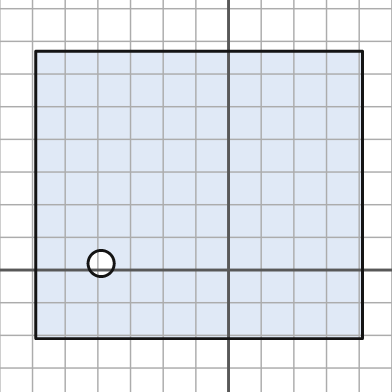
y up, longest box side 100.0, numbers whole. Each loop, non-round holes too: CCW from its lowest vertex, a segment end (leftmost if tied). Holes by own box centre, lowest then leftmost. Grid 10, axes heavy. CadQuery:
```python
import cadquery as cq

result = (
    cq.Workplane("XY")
    .moveTo(-59.0, -21.0)
    .lineTo(41.0, -21.0)
    .lineTo(41.0, 67.0)
    .lineTo(-59.0, 67.0)
    .close()
    .moveTo(-39.0, 2.0)
    .circle(4.0)
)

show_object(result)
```